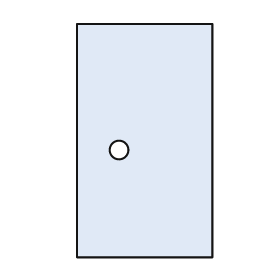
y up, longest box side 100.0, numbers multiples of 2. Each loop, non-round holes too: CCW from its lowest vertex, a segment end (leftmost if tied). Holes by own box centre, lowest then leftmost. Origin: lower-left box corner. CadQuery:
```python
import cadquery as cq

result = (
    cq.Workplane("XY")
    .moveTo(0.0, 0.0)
    .lineTo(58.0, 0.0)
    .lineTo(58.0, 100.0)
    .lineTo(0.0, 100.0)
    .close()
    .moveTo(18.0, 46.0)
    .circle(4.0)
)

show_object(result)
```